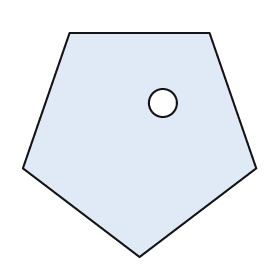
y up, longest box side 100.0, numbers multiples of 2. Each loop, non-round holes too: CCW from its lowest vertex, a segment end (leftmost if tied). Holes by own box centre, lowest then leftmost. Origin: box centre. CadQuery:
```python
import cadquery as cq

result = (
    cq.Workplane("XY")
    .moveTo(0.0, -48.0)
    .lineTo(50.0, -10.0)
    .lineTo(30.0, 48.0)
    .lineTo(-30.0, 48.0)
    .lineTo(-50.0, -10.0)
    .close()
    .moveTo(10.0, 18.0)
    .circle(6.0)
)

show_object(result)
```